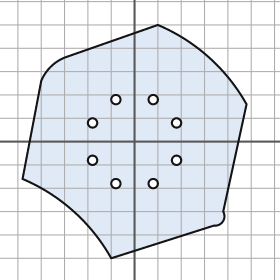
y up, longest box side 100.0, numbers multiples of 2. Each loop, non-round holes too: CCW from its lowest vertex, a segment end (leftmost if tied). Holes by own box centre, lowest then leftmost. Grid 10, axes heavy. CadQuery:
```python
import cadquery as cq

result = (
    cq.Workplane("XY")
    .moveTo(-10.0, -50.0)
    .lineTo(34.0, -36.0)
    .threePointArc((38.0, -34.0), (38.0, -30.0))
    .lineTo(48.0, 16.0)
    .threePointArc((32.0, 36.0), (10.0, 50.0))
    .lineTo(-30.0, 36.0)
    .threePointArc((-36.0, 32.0), (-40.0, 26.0))
    .lineTo(-48.0, -16.0)
    .threePointArc((-26.0, -30.0), (-10.0, -50.0))
    .close()
    .moveTo(-8.0, -18.0)
    .circle(2.0)
    .moveTo(8.0, -18.0)
    .circle(2.0)
    .moveTo(-18.0, -8.0)
    .circle(2.0)
    .moveTo(18.0, -8.0)
    .circle(2.0)
    .moveTo(-18.0, 8.0)
    .circle(2.0)
    .moveTo(18.0, 8.0)
    .circle(2.0)
    .moveTo(-8.0, 18.0)
    .circle(2.0)
    .moveTo(8.0, 18.0)
    .circle(2.0)
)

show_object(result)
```